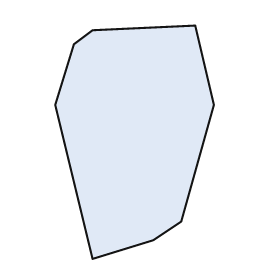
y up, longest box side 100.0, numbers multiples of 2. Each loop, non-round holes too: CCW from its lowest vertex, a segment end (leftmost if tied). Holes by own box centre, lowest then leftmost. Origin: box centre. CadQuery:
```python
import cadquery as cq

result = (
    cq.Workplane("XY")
    .moveTo(-18.0, -50.0)
    .lineTo(8.0, -42.0)
    .lineTo(20.0, -34.0)
    .lineTo(34.0, 16.0)
    .lineTo(26.0, 50.0)
    .lineTo(-18.0, 48.0)
    .lineTo(-26.0, 42.0)
    .lineTo(-34.0, 16.0)
    .close()
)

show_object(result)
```